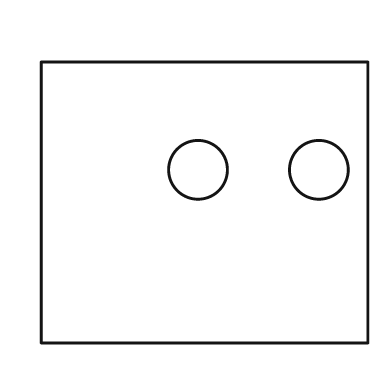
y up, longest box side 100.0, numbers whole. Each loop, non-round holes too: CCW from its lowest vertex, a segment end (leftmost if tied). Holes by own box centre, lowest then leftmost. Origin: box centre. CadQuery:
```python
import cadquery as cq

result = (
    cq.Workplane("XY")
    .moveTo(-50.0, -43.0)
    .lineTo(50.0, -43.0)
    .lineTo(50.0, 43.0)
    .lineTo(-50.0, 43.0)
    .close()
    .moveTo(-2.0, 10.0)
    .circle(9.0)
    .moveTo(35.0, 10.0)
    .circle(9.0)
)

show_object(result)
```